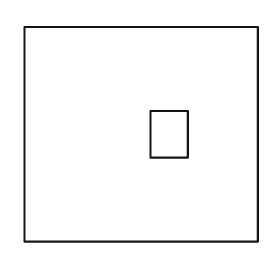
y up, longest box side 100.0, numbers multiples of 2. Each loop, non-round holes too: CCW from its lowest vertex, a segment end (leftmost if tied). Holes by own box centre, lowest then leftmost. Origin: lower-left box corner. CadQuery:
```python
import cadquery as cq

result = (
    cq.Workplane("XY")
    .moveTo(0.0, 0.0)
    .lineTo(100.0, 0.0)
    .lineTo(100.0, 92.0)
    .lineTo(0.0, 92.0)
    .close()
    .moveTo(54.0, 36.0)
    .lineTo(70.0, 36.0)
    .lineTo(70.0, 56.0)
    .lineTo(54.0, 56.0)
    .close()
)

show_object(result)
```